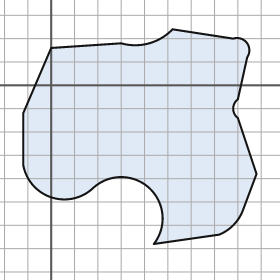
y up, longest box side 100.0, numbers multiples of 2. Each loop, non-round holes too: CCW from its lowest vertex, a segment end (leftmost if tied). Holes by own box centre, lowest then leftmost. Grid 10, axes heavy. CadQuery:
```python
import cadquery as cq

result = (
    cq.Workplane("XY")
    .moveTo(44.0, -68.0)
    .lineTo(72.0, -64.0)
    .threePointArc((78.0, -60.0), (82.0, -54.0))
    .lineTo(88.0, -38.0)
    .lineTo(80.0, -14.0)
    .threePointArc((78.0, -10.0), (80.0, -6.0))
    .lineTo(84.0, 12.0)
    .threePointArc((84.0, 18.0), (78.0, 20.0))
    .lineTo(52.0, 24.0)
    .threePointArc((42.0, 18.0), (30.0, 18.0))
    .lineTo(0.0, 16.0)
    .lineTo(-12.0, -12.0)
    .lineTo(-12.0, -34.0)
    .threePointArc((0.0, -48.0), (18.0, -44.0))
    .threePointArc((42.0, -44.0), (44.0, -68.0))
    .close()
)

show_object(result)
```